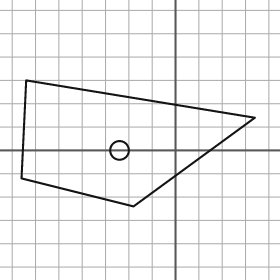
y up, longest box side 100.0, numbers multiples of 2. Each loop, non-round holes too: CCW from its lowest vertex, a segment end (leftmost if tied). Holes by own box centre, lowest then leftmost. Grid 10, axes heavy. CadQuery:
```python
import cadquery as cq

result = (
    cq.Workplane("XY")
    .moveTo(-18.0, -24.0)
    .lineTo(34.0, 14.0)
    .lineTo(-64.0, 30.0)
    .lineTo(-66.0, -12.0)
    .close()
    .moveTo(-24.0, 0.0)
    .circle(4.0)
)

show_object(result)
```